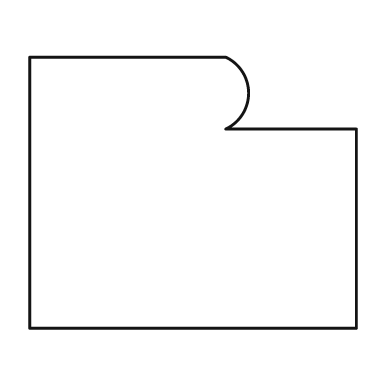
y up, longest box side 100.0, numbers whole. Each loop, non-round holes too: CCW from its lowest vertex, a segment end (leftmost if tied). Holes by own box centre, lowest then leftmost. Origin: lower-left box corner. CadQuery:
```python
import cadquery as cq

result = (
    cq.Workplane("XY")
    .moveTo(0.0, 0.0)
    .lineTo(100.0, 0.0)
    .lineTo(100.0, 61.0)
    .lineTo(60.0, 61.0)
    .threePointArc((67.0, 72.0), (60.0, 83.0))
    .lineTo(0.0, 83.0)
    .close()
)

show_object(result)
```